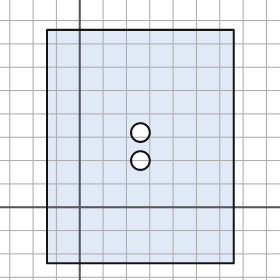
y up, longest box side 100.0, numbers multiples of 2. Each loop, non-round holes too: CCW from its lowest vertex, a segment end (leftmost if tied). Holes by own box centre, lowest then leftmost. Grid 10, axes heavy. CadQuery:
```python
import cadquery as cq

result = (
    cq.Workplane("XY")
    .moveTo(-14.0, -24.0)
    .lineTo(66.0, -24.0)
    .lineTo(66.0, 76.0)
    .lineTo(-14.0, 76.0)
    .close()
    .moveTo(26.0, 20.0)
    .circle(4.0)
    .moveTo(26.0, 32.0)
    .circle(4.0)
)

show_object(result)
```